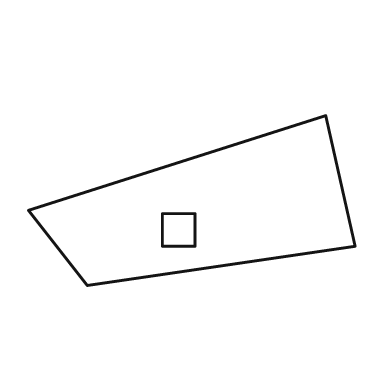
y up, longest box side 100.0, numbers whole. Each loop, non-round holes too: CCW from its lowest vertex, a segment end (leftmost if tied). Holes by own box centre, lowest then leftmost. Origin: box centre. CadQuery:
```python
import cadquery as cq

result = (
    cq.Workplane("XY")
    .moveTo(-32.0, -26.0)
    .lineTo(50.0, -14.0)
    .lineTo(41.0, 26.0)
    .lineTo(-50.0, -3.0)
    .close()
    .moveTo(-9.0, -14.0)
    .lineTo(1.0, -14.0)
    .lineTo(1.0, -4.0)
    .lineTo(-9.0, -4.0)
    .close()
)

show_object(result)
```